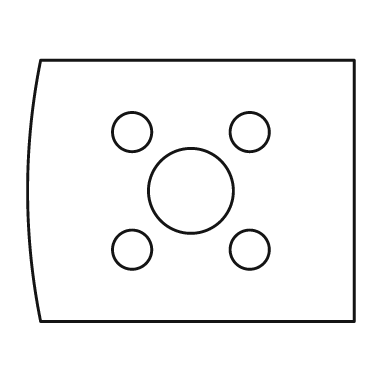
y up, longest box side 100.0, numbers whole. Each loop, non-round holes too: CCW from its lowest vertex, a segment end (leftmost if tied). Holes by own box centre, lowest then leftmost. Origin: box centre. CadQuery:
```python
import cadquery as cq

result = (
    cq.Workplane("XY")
    .moveTo(-46.0, -40.0)
    .lineTo(50.0, -40.0)
    .lineTo(50.0, 40.0)
    .lineTo(-46.0, 40.0)
    .threePointArc((-50.0, 0.0), (-46.0, -40.0))
    .close()
    .moveTo(-18.0, -18.0)
    .circle(6.0)
    .moveTo(18.0, -18.0)
    .circle(6.0)
    .moveTo(0.0, 0.0)
    .circle(13.0)
    .moveTo(-18.0, 18.0)
    .circle(6.0)
    .moveTo(18.0, 18.0)
    .circle(6.0)
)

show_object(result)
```